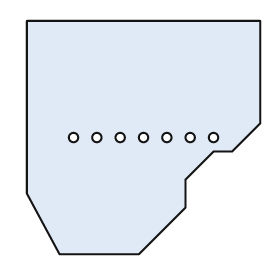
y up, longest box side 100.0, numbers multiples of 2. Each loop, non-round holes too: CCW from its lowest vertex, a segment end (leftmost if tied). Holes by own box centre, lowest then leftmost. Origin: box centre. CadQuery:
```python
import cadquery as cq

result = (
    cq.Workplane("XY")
    .moveTo(-36.0, -50.0)
    .lineTo(-2.0, -50.0)
    .lineTo(18.0, -30.0)
    .lineTo(18.0, -18.0)
    .lineTo(30.0, -6.0)
    .lineTo(38.0, -6.0)
    .lineTo(50.0, 6.0)
    .lineTo(50.0, 50.0)
    .lineTo(-50.0, 50.0)
    .lineTo(-50.0, -24.0)
    .close()
    .moveTo(-30.0, 0.0)
    .circle(2.0)
    .moveTo(-20.0, 0.0)
    .circle(2.0)
    .moveTo(-10.0, 0.0)
    .circle(2.0)
    .moveTo(0.0, 0.0)
    .circle(2.0)
    .moveTo(10.0, 0.0)
    .circle(2.0)
    .moveTo(20.0, 0.0)
    .circle(2.0)
    .moveTo(30.0, 0.0)
    .circle(2.0)
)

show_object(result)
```